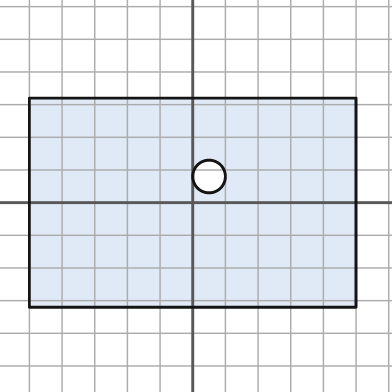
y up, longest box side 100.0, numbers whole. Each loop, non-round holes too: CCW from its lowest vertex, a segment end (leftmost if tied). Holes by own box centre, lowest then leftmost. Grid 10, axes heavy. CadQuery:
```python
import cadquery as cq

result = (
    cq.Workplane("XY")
    .moveTo(-50.0, -32.0)
    .lineTo(50.0, -32.0)
    .lineTo(50.0, 32.0)
    .lineTo(-50.0, 32.0)
    .close()
    .moveTo(5.0, 8.0)
    .circle(5.0)
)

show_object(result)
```